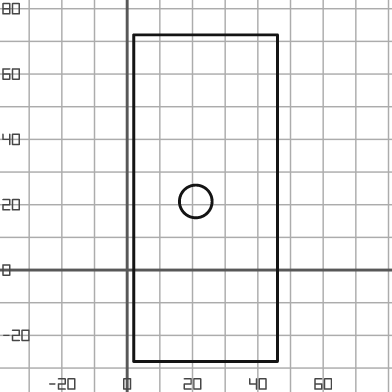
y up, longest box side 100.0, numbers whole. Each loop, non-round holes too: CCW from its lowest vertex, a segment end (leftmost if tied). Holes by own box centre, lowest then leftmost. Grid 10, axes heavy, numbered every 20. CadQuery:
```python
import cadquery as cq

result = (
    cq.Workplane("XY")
    .moveTo(2.0, -28.0)
    .lineTo(46.0, -28.0)
    .lineTo(46.0, 72.0)
    .lineTo(2.0, 72.0)
    .close()
    .moveTo(21.0, 21.0)
    .circle(5.0)
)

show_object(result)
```